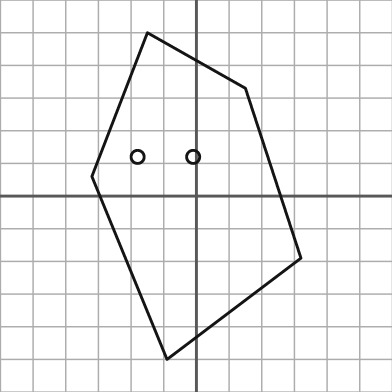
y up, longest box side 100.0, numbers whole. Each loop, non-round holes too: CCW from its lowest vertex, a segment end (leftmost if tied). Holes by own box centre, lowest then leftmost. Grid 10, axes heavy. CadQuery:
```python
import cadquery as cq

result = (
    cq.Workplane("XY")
    .moveTo(-9.0, -50.0)
    .lineTo(32.0, -19.0)
    .lineTo(15.0, 33.0)
    .lineTo(-15.0, 50.0)
    .lineTo(-32.0, 6.0)
    .close()
    .moveTo(-18.0, 12.0)
    .circle(2.0)
    .moveTo(-1.0, 12.0)
    .circle(2.0)
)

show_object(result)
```